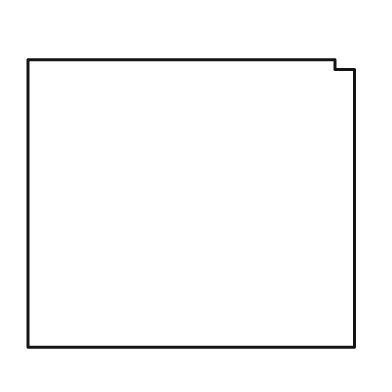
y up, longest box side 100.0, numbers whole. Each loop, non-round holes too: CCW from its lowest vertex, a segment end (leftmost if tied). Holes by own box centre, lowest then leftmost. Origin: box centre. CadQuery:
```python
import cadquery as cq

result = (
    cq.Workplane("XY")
    .moveTo(-50.0, -44.0)
    .lineTo(50.0, -44.0)
    .lineTo(50.0, 41.0)
    .lineTo(44.0, 41.0)
    .lineTo(44.0, 44.0)
    .lineTo(-50.0, 44.0)
    .close()
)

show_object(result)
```